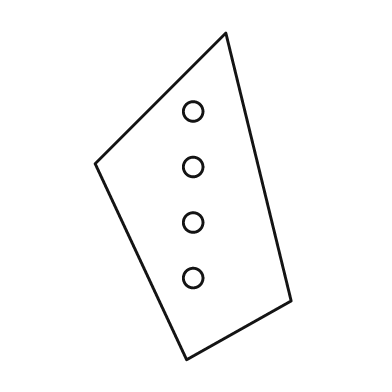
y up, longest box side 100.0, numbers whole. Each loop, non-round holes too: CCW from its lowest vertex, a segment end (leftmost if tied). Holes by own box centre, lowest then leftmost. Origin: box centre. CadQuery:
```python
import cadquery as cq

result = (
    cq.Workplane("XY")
    .moveTo(-2.0, -50.0)
    .lineTo(30.0, -32.0)
    .lineTo(10.0, 50.0)
    .lineTo(-30.0, 10.0)
    .close()
    .moveTo(0.0, -25.0)
    .circle(3.0)
    .moveTo(0.0, -8.0)
    .circle(3.0)
    .moveTo(0.0, 9.0)
    .circle(3.0)
    .moveTo(0.0, 26.0)
    .circle(3.0)
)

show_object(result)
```